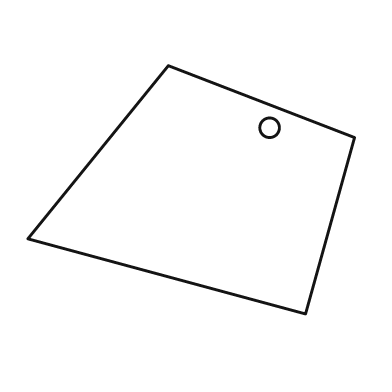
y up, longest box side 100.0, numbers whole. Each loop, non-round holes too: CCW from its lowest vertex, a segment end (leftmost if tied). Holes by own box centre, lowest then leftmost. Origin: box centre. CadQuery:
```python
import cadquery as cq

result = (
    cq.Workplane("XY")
    .moveTo(35.0, -38.0)
    .lineTo(50.0, 16.0)
    .lineTo(-7.0, 38.0)
    .lineTo(-50.0, -15.0)
    .close()
    .moveTo(24.0, 19.0)
    .circle(3.0)
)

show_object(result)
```